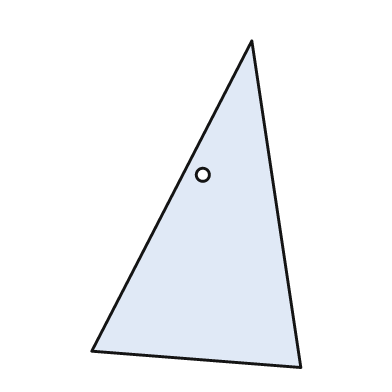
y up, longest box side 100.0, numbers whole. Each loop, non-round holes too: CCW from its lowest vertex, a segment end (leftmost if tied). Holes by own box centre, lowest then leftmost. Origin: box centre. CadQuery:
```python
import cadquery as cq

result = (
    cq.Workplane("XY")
    .moveTo(32.0, -50.0)
    .lineTo(17.0, 50.0)
    .lineTo(-32.0, -45.0)
    .close()
    .moveTo(2.0, 9.0)
    .circle(2.0)
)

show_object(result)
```